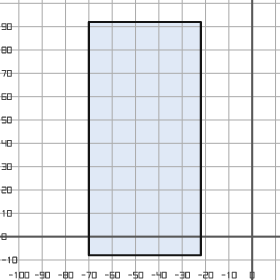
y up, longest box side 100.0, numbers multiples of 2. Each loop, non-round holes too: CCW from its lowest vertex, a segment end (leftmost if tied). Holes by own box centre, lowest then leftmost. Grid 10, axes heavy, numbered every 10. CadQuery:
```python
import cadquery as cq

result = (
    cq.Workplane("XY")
    .moveTo(-70.0, -8.0)
    .lineTo(-22.0, -8.0)
    .lineTo(-22.0, 92.0)
    .lineTo(-70.0, 92.0)
    .close()
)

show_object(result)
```